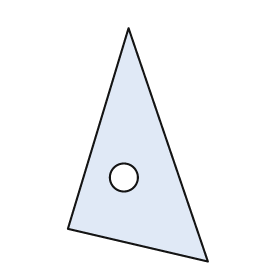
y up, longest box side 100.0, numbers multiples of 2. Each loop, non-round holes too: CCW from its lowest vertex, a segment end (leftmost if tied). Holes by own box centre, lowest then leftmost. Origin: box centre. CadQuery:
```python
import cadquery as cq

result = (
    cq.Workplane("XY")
    .moveTo(30.0, -50.0)
    .lineTo(-4.0, 50.0)
    .lineTo(-30.0, -36.0)
    .close()
    .moveTo(-6.0, -14.0)
    .circle(6.0)
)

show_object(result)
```